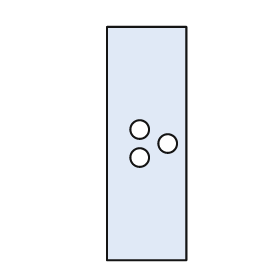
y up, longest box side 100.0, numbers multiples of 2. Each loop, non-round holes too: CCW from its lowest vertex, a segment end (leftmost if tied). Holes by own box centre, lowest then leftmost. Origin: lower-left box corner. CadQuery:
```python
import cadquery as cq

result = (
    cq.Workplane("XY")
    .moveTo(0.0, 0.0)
    .lineTo(34.0, 0.0)
    .lineTo(34.0, 100.0)
    .lineTo(0.0, 100.0)
    .close()
    .moveTo(14.0, 44.0)
    .circle(4.0)
    .moveTo(26.0, 50.0)
    .circle(4.0)
    .moveTo(14.0, 56.0)
    .circle(4.0)
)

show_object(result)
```